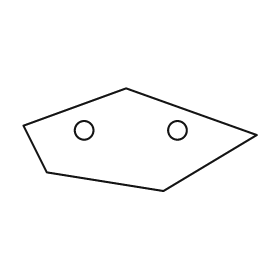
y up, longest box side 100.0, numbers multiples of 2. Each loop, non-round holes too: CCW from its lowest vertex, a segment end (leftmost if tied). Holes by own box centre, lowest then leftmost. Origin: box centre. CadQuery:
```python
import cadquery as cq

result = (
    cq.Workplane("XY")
    .moveTo(10.0, -22.0)
    .lineTo(50.0, 2.0)
    .lineTo(-6.0, 22.0)
    .lineTo(-50.0, 6.0)
    .lineTo(-40.0, -14.0)
    .close()
    .moveTo(-24.0, 4.0)
    .circle(4.0)
    .moveTo(16.0, 4.0)
    .circle(4.0)
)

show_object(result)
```